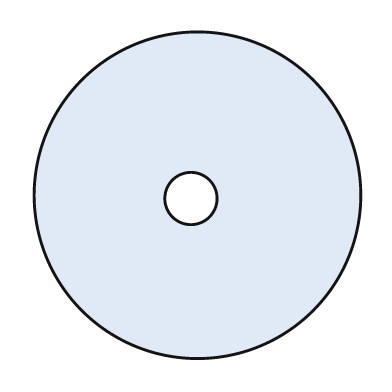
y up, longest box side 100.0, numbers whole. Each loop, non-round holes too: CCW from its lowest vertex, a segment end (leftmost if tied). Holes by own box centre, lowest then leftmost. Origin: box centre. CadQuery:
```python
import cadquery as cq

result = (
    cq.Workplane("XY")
    .moveTo(0.0, 0.0)
    .circle(50.0)
    .moveTo(-2.0, -1.0)
    .circle(8.0)
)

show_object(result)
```